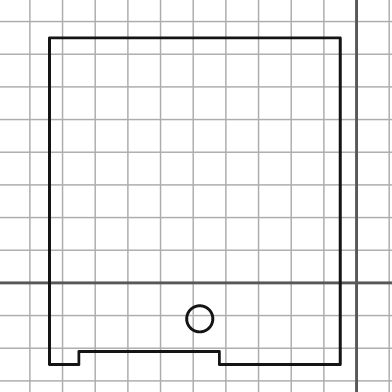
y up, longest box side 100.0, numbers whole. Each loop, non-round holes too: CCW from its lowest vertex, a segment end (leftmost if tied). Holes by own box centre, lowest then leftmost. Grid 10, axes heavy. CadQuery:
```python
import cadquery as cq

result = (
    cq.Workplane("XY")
    .moveTo(-94.0, -25.0)
    .lineTo(-85.0, -25.0)
    .lineTo(-85.0, -21.0)
    .lineTo(-42.0, -21.0)
    .lineTo(-42.0, -25.0)
    .lineTo(-5.0, -25.0)
    .lineTo(-5.0, 75.0)
    .lineTo(-94.0, 75.0)
    .close()
    .moveTo(-48.0, -11.0)
    .circle(4.0)
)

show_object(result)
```